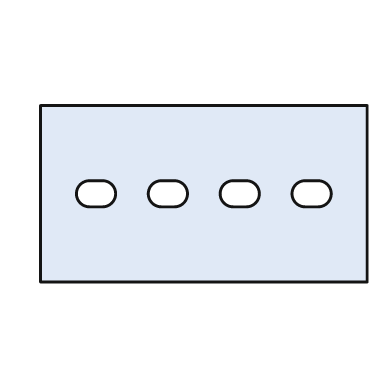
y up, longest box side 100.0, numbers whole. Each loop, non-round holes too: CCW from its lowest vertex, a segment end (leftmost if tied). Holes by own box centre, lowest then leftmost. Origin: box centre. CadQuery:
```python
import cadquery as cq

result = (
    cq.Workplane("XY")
    .moveTo(-50.0, -27.0)
    .lineTo(50.0, -27.0)
    .lineTo(50.0, 27.0)
    .lineTo(-50.0, 27.0)
    .close()
    .moveTo(-35.0, -4.0)
    .lineTo(-31.0, -4.0)
    .threePointArc((-27.0, 0.0), (-31.0, 4.0))
    .lineTo(-35.0, 4.0)
    .threePointArc((-39.0, 0.0), (-35.0, -4.0))
    .close()
    .moveTo(-13.0, -4.0)
    .lineTo(-9.0, -4.0)
    .threePointArc((-5.0, 0.0), (-9.0, 4.0))
    .lineTo(-13.0, 4.0)
    .threePointArc((-17.0, 0.0), (-13.0, -4.0))
    .close()
    .moveTo(9.0, -4.0)
    .lineTo(13.0, -4.0)
    .threePointArc((17.0, 0.0), (13.0, 4.0))
    .lineTo(9.0, 4.0)
    .threePointArc((5.0, 0.0), (9.0, -4.0))
    .close()
    .moveTo(31.0, -4.0)
    .lineTo(35.0, -4.0)
    .threePointArc((39.0, 0.0), (35.0, 4.0))
    .lineTo(31.0, 4.0)
    .threePointArc((27.0, 0.0), (31.0, -4.0))
    .close()
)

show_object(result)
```